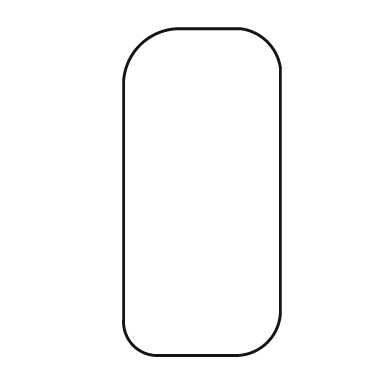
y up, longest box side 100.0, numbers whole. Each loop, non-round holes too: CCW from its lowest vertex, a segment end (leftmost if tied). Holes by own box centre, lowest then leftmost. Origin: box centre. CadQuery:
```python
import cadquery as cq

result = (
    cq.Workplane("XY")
    .moveTo(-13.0, -50.0)
    .lineTo(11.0, -50.0)
    .threePointArc((20.0, -46.0), (24.0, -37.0))
    .lineTo(24.0, 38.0)
    .threePointArc((20.0, 46.0), (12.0, 50.0))
    .lineTo(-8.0, 50.0)
    .threePointArc((-19.0, 45.0), (-24.0, 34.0))
    .lineTo(-24.0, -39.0)
    .threePointArc((-21.0, -47.0), (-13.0, -50.0))
    .close()
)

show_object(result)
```